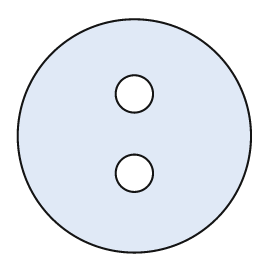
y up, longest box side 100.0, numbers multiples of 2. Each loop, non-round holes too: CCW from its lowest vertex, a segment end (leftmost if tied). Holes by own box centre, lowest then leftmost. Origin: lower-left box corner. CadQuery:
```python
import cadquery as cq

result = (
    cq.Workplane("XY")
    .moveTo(50.0, 50.0)
    .circle(50.0)
    .moveTo(50.0, 34.0)
    .circle(8.0)
    .moveTo(50.0, 68.0)
    .circle(8.0)
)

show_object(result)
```